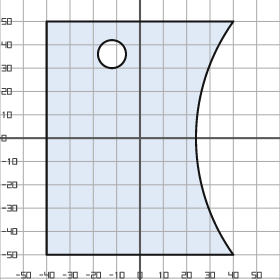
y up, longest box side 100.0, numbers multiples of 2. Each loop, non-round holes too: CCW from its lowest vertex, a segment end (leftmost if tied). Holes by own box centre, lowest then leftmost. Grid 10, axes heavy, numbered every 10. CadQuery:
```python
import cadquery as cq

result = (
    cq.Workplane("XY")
    .moveTo(-40.0, -50.0)
    .lineTo(40.0, -50.0)
    .threePointArc((24.0, 0.0), (40.0, 50.0))
    .lineTo(-40.0, 50.0)
    .close()
    .moveTo(-12.0, 36.0)
    .circle(6.0)
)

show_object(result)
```